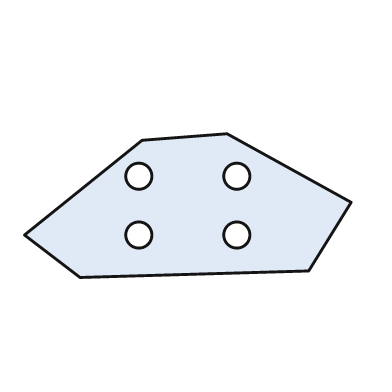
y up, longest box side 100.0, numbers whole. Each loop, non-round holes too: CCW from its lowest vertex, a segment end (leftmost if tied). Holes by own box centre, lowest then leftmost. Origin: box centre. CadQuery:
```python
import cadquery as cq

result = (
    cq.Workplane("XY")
    .moveTo(-33.0, -22.0)
    .lineTo(37.0, -20.0)
    .lineTo(50.0, 1.0)
    .lineTo(12.0, 22.0)
    .lineTo(-14.0, 20.0)
    .lineTo(-50.0, -9.0)
    .close()
    .moveTo(-15.0, -9.0)
    .circle(4.0)
    .moveTo(15.0, -9.0)
    .circle(4.0)
    .moveTo(-15.0, 9.0)
    .circle(4.0)
    .moveTo(15.0, 9.0)
    .circle(4.0)
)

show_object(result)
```